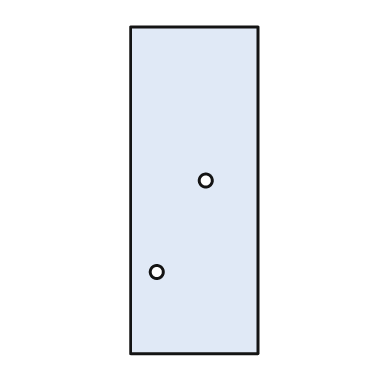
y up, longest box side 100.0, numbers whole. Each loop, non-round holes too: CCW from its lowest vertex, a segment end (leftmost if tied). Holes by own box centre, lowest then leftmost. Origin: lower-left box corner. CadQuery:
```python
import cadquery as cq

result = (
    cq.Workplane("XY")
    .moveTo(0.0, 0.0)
    .lineTo(39.0, 0.0)
    .lineTo(39.0, 100.0)
    .lineTo(0.0, 100.0)
    .close()
    .moveTo(8.0, 25.0)
    .circle(2.0)
    .moveTo(23.0, 53.0)
    .circle(2.0)
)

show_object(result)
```